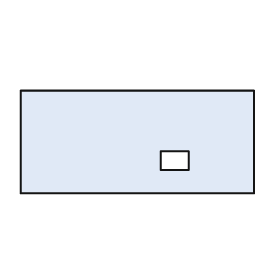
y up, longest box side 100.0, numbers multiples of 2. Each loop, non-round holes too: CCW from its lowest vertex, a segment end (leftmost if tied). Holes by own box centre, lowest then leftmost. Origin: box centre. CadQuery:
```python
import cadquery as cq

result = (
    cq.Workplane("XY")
    .moveTo(-50.0, -22.0)
    .lineTo(50.0, -22.0)
    .lineTo(50.0, 22.0)
    .lineTo(-50.0, 22.0)
    .close()
    .moveTo(10.0, -12.0)
    .lineTo(22.0, -12.0)
    .lineTo(22.0, -4.0)
    .lineTo(10.0, -4.0)
    .close()
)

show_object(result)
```